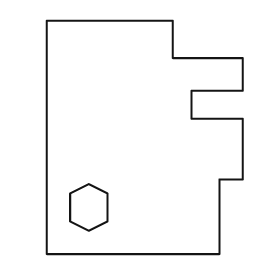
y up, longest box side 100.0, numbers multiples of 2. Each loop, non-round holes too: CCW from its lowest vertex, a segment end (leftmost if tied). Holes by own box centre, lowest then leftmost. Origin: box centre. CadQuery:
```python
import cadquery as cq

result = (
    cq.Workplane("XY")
    .moveTo(-42.0, -50.0)
    .lineTo(32.0, -50.0)
    .lineTo(32.0, -18.0)
    .lineTo(42.0, -18.0)
    .lineTo(42.0, 8.0)
    .lineTo(20.0, 8.0)
    .lineTo(20.0, 20.0)
    .lineTo(42.0, 20.0)
    .lineTo(42.0, 34.0)
    .lineTo(12.0, 34.0)
    .lineTo(12.0, 50.0)
    .lineTo(-42.0, 50.0)
    .close()
    .moveTo(-24.0, -40.0)
    .lineTo(-16.0, -36.0)
    .lineTo(-16.0, -24.0)
    .lineTo(-24.0, -20.0)
    .lineTo(-32.0, -24.0)
    .lineTo(-32.0, -36.0)
    .close()
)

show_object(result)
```